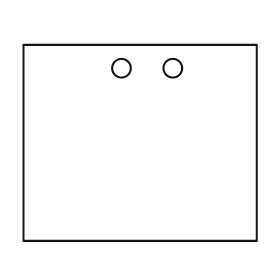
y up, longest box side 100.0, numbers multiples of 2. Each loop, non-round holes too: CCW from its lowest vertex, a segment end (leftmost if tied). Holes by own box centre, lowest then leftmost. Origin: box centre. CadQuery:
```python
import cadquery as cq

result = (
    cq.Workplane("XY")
    .moveTo(-50.0, -42.0)
    .lineTo(50.0, -42.0)
    .lineTo(50.0, 42.0)
    .lineTo(-50.0, 42.0)
    .close()
    .moveTo(-8.0, 32.0)
    .circle(4.0)
    .moveTo(14.0, 32.0)
    .circle(4.0)
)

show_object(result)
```